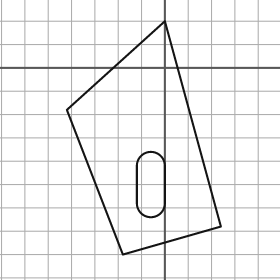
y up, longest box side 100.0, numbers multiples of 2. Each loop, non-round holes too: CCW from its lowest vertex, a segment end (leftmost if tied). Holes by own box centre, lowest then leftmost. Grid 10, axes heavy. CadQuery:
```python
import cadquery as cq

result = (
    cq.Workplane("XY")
    .moveTo(-18.0, -80.0)
    .lineTo(24.0, -68.0)
    .lineTo(0.0, 20.0)
    .lineTo(-42.0, -18.0)
    .close()
    .moveTo(-12.0, -58.0)
    .threePointArc((-6.0, -64.0), (0.0, -58.0))
    .lineTo(0.0, -42.0)
    .threePointArc((-6.0, -36.0), (-12.0, -42.0))
    .close()
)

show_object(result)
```